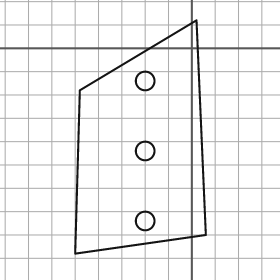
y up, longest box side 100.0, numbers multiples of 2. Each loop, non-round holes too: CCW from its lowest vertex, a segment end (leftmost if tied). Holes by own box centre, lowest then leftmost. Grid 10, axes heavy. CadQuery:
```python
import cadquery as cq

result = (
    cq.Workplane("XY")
    .moveTo(-50.0, -88.0)
    .lineTo(6.0, -80.0)
    .lineTo(2.0, 12.0)
    .lineTo(-48.0, -18.0)
    .close()
    .moveTo(-20.0, -74.0)
    .circle(4.0)
    .moveTo(-20.0, -44.0)
    .circle(4.0)
    .moveTo(-20.0, -14.0)
    .circle(4.0)
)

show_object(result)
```